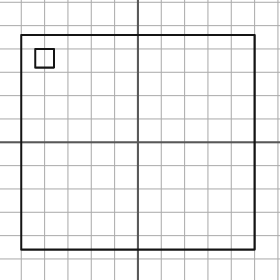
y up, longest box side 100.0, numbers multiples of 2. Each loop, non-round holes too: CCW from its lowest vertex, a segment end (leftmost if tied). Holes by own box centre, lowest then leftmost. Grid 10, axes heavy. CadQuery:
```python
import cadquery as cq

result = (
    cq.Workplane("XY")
    .moveTo(-50.0, -46.0)
    .lineTo(50.0, -46.0)
    .lineTo(50.0, 46.0)
    .lineTo(-50.0, 46.0)
    .close()
    .moveTo(-44.0, 32.0)
    .lineTo(-36.0, 32.0)
    .lineTo(-36.0, 40.0)
    .lineTo(-44.0, 40.0)
    .close()
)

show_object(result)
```